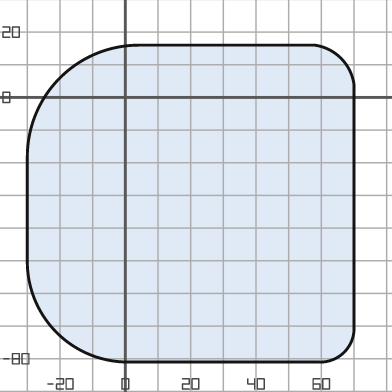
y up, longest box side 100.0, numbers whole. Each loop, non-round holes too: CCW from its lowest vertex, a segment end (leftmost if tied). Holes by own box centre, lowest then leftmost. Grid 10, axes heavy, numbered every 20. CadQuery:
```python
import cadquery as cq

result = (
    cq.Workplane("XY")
    .moveTo(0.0, -81.0)
    .lineTo(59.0, -81.0)
    .threePointArc((67.0, -78.0), (70.0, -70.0))
    .lineTo(70.0, 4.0)
    .threePointArc((66.0, 12.0), (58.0, 16.0))
    .lineTo(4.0, 16.0)
    .threePointArc((-20.0, 6.0), (-30.0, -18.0))
    .lineTo(-30.0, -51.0)
    .threePointArc((-21.0, -72.0), (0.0, -81.0))
    .close()
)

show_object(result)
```